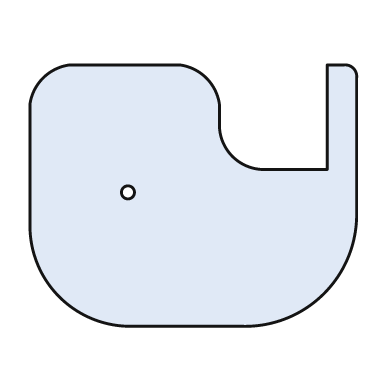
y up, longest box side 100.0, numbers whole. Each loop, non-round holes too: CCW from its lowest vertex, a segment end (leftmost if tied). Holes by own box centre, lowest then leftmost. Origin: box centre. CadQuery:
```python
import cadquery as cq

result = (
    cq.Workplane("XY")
    .moveTo(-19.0, -40.0)
    .lineTo(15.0, -40.0)
    .threePointArc((40.0, -30.0), (50.0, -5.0))
    .lineTo(50.0, 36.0)
    .threePointArc((49.0, 39.0), (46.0, 40.0))
    .lineTo(41.0, 40.0)
    .lineTo(41.0, 8.0)
    .lineTo(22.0, 8.0)
    .threePointArc((12.0, 12.0), (8.0, 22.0))
    .lineTo(8.0, 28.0)
    .threePointArc((4.0, 36.0), (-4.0, 40.0))
    .lineTo(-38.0, 40.0)
    .threePointArc((-46.0, 36.0), (-50.0, 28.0))
    .lineTo(-50.0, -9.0)
    .threePointArc((-41.0, -31.0), (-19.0, -40.0))
    .close()
    .moveTo(-20.0, 1.0)
    .circle(2.0)
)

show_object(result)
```